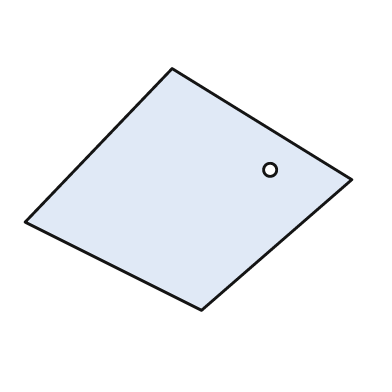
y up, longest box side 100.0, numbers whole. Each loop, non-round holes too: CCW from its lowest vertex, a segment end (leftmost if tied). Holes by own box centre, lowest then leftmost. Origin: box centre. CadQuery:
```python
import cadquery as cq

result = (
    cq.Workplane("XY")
    .moveTo(4.0, -37.0)
    .lineTo(50.0, 3.0)
    .lineTo(-5.0, 37.0)
    .lineTo(-50.0, -10.0)
    .close()
    .moveTo(25.0, 6.0)
    .circle(2.0)
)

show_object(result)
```